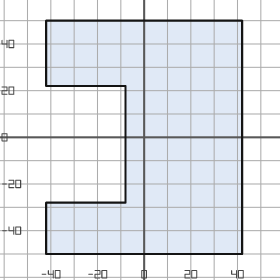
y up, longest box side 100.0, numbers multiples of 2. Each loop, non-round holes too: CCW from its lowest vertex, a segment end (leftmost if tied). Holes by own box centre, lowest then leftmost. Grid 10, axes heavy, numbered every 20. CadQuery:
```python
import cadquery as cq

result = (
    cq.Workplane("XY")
    .moveTo(-42.0, -50.0)
    .lineTo(42.0, -50.0)
    .lineTo(42.0, 50.0)
    .lineTo(-42.0, 50.0)
    .lineTo(-42.0, 22.0)
    .lineTo(-8.0, 22.0)
    .lineTo(-8.0, -28.0)
    .lineTo(-42.0, -28.0)
    .close()
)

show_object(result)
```